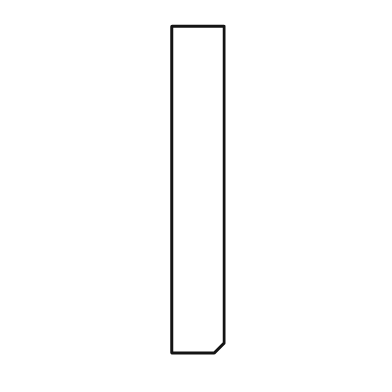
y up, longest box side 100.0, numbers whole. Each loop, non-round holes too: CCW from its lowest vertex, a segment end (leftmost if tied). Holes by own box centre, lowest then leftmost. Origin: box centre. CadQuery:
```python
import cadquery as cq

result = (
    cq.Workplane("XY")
    .moveTo(-8.0, -50.0)
    .lineTo(5.0, -50.0)
    .lineTo(8.0, -47.0)
    .lineTo(8.0, 50.0)
    .lineTo(-8.0, 50.0)
    .close()
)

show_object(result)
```